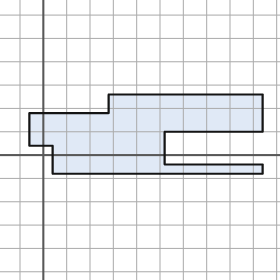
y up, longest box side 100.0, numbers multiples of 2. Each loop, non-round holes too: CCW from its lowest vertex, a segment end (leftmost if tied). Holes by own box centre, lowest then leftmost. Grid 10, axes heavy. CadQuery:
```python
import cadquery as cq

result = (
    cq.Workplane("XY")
    .moveTo(4.0, -8.0)
    .lineTo(94.0, -8.0)
    .lineTo(94.0, -4.0)
    .lineTo(52.0, -4.0)
    .lineTo(52.0, 10.0)
    .lineTo(94.0, 10.0)
    .lineTo(94.0, 26.0)
    .lineTo(28.0, 26.0)
    .lineTo(28.0, 18.0)
    .lineTo(-6.0, 18.0)
    .lineTo(-6.0, 4.0)
    .lineTo(4.0, 4.0)
    .close()
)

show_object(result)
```